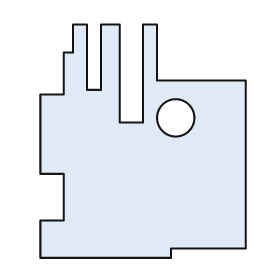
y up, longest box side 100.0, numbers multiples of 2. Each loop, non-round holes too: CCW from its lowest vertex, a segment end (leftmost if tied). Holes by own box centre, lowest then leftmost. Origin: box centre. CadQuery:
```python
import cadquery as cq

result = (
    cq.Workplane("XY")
    .moveTo(-44.0, -50.0)
    .lineTo(12.0, -50.0)
    .lineTo(12.0, -46.0)
    .lineTo(44.0, -46.0)
    .lineTo(44.0, 26.0)
    .lineTo(6.0, 26.0)
    .lineTo(6.0, 50.0)
    .lineTo(0.0, 50.0)
    .lineTo(0.0, 8.0)
    .lineTo(-10.0, 8.0)
    .lineTo(-10.0, 50.0)
    .lineTo(-18.0, 50.0)
    .lineTo(-18.0, 22.0)
    .lineTo(-24.0, 22.0)
    .lineTo(-24.0, 50.0)
    .lineTo(-30.0, 50.0)
    .lineTo(-30.0, 38.0)
    .lineTo(-34.0, 38.0)
    .lineTo(-34.0, 20.0)
    .lineTo(-44.0, 20.0)
    .lineTo(-44.0, -14.0)
    .lineTo(-34.0, -14.0)
    .lineTo(-34.0, -34.0)
    .lineTo(-44.0, -34.0)
    .close()
    .moveTo(14.0, 10.0)
    .circle(8.0)
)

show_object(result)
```